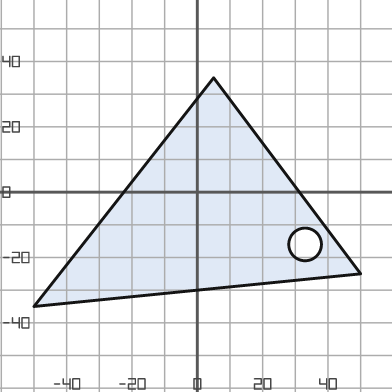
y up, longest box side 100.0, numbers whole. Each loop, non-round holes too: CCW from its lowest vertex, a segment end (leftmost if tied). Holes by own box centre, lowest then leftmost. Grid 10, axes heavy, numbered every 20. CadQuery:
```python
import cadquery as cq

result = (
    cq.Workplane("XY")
    .moveTo(-50.0, -35.0)
    .lineTo(50.0, -25.0)
    .lineTo(5.0, 35.0)
    .close()
    .moveTo(33.0, -16.0)
    .circle(5.0)
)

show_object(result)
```